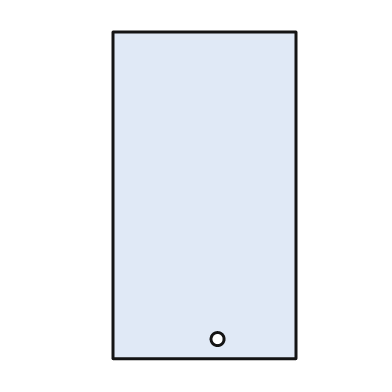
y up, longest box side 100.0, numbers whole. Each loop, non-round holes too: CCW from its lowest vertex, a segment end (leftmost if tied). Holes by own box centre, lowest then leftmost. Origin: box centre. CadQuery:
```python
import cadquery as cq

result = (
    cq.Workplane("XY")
    .moveTo(-28.0, -50.0)
    .lineTo(28.0, -50.0)
    .lineTo(28.0, 50.0)
    .lineTo(-28.0, 50.0)
    .close()
    .moveTo(4.0, -44.0)
    .circle(2.0)
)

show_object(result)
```